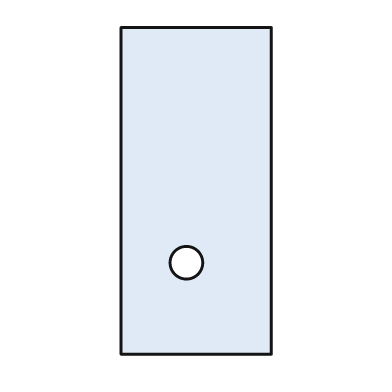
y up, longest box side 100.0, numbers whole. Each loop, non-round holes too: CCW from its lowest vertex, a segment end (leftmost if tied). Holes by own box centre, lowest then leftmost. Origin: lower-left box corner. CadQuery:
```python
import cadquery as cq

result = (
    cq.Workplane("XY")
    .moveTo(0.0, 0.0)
    .lineTo(46.0, 0.0)
    .lineTo(46.0, 100.0)
    .lineTo(0.0, 100.0)
    .close()
    .moveTo(20.0, 28.0)
    .circle(5.0)
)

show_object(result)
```